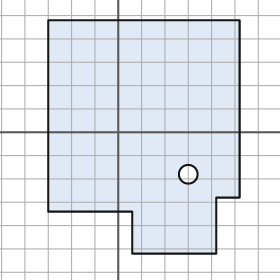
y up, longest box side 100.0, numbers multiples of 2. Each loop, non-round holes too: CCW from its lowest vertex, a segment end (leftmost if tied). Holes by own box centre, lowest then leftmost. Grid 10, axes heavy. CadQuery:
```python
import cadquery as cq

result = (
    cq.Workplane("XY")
    .moveTo(6.0, -52.0)
    .lineTo(42.0, -52.0)
    .lineTo(42.0, -28.0)
    .lineTo(52.0, -28.0)
    .lineTo(52.0, 48.0)
    .lineTo(-30.0, 48.0)
    .lineTo(-30.0, -34.0)
    .lineTo(6.0, -34.0)
    .close()
    .moveTo(30.0, -18.0)
    .circle(4.0)
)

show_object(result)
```